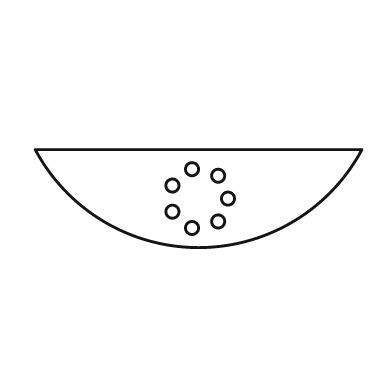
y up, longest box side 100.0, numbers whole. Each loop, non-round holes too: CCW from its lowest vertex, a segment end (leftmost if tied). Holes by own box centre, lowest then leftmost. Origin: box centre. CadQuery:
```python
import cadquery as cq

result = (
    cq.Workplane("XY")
    .moveTo(-50.0, 15.0)
    .threePointArc((0.0, -15.0), (50.0, 15.0))
    .close()
    .moveTo(-2.0, -9.0)
    .circle(2.0)
    .moveTo(6.0, -7.0)
    .circle(2.0)
    .moveTo(-8.0, -4.0)
    .circle(2.0)
    .moveTo(9.0, 0.0)
    .circle(2.0)
    .moveTo(-8.0, 4.0)
    .circle(2.0)
    .moveTo(6.0, 7.0)
    .circle(2.0)
    .moveTo(-2.0, 9.0)
    .circle(2.0)
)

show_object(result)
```